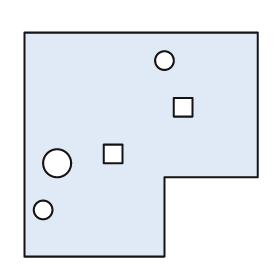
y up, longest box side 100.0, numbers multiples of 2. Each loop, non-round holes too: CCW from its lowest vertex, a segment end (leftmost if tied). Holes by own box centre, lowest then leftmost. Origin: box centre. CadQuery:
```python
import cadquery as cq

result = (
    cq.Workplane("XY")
    .moveTo(-50.0, -48.0)
    .lineTo(10.0, -48.0)
    .lineTo(10.0, -14.0)
    .lineTo(50.0, -14.0)
    .lineTo(50.0, 48.0)
    .lineTo(-50.0, 48.0)
    .close()
    .moveTo(-42.0, -28.0)
    .circle(4.0)
    .moveTo(-36.0, -8.0)
    .circle(6.0)
    .moveTo(-16.0, -8.0)
    .lineTo(-8.0, -8.0)
    .lineTo(-8.0, 0.0)
    .lineTo(-16.0, 0.0)
    .close()
    .moveTo(14.0, 12.0)
    .lineTo(22.0, 12.0)
    .lineTo(22.0, 20.0)
    .lineTo(14.0, 20.0)
    .close()
    .moveTo(10.0, 36.0)
    .circle(4.0)
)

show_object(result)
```